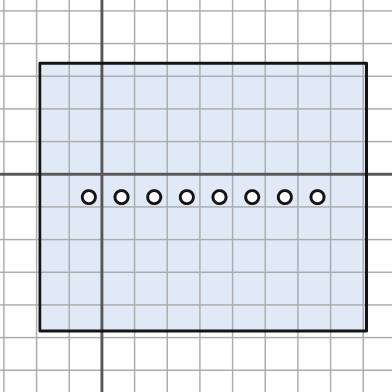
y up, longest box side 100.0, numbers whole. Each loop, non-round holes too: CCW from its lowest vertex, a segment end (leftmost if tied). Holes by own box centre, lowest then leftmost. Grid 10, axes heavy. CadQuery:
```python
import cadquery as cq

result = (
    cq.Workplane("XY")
    .moveTo(-19.0, -48.0)
    .lineTo(81.0, -48.0)
    .lineTo(81.0, 34.0)
    .lineTo(-19.0, 34.0)
    .close()
    .moveTo(-4.0, -7.0)
    .circle(2.0)
    .moveTo(6.0, -7.0)
    .circle(2.0)
    .moveTo(16.0, -7.0)
    .circle(2.0)
    .moveTo(26.0, -7.0)
    .circle(2.0)
    .moveTo(36.0, -7.0)
    .circle(2.0)
    .moveTo(46.0, -7.0)
    .circle(2.0)
    .moveTo(56.0, -7.0)
    .circle(2.0)
    .moveTo(66.0, -7.0)
    .circle(2.0)
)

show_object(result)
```